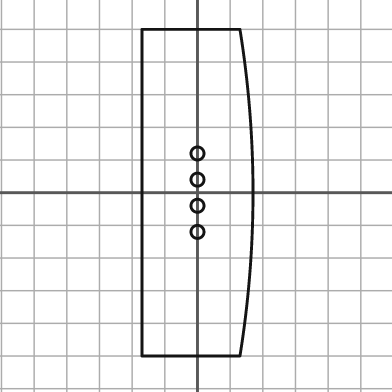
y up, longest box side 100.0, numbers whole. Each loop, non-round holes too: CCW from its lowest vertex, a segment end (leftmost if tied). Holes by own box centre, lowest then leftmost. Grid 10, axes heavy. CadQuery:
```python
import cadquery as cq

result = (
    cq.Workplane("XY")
    .moveTo(-17.0, -50.0)
    .lineTo(13.0, -50.0)
    .threePointArc((17.0, 0.0), (13.0, 50.0))
    .lineTo(-17.0, 50.0)
    .close()
    .moveTo(0.0, -12.0)
    .circle(2.0)
    .moveTo(0.0, -4.0)
    .circle(2.0)
    .moveTo(0.0, 4.0)
    .circle(2.0)
    .moveTo(0.0, 12.0)
    .circle(2.0)
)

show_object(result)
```